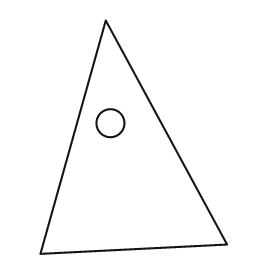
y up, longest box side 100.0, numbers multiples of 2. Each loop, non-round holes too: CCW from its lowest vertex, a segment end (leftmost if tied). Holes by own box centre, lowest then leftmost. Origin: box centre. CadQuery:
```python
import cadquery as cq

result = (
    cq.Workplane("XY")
    .moveTo(-40.0, -50.0)
    .lineTo(40.0, -46.0)
    .lineTo(-12.0, 50.0)
    .close()
    .moveTo(-10.0, 6.0)
    .circle(6.0)
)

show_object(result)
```